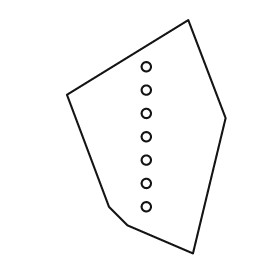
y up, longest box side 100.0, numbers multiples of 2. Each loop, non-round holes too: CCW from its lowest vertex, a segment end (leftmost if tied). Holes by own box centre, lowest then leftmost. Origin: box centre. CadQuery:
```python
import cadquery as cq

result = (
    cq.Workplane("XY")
    .moveTo(20.0, -50.0)
    .lineTo(34.0, 8.0)
    .lineTo(18.0, 50.0)
    .lineTo(-34.0, 18.0)
    .lineTo(-16.0, -30.0)
    .lineTo(-8.0, -38.0)
    .close()
    .moveTo(0.0, -30.0)
    .circle(2.0)
    .moveTo(0.0, -20.0)
    .circle(2.0)
    .moveTo(0.0, -10.0)
    .circle(2.0)
    .moveTo(0.0, 0.0)
    .circle(2.0)
    .moveTo(0.0, 10.0)
    .circle(2.0)
    .moveTo(0.0, 20.0)
    .circle(2.0)
    .moveTo(0.0, 30.0)
    .circle(2.0)
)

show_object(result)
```